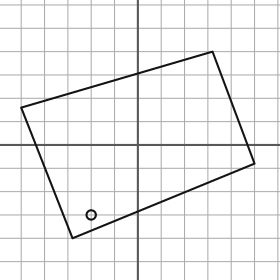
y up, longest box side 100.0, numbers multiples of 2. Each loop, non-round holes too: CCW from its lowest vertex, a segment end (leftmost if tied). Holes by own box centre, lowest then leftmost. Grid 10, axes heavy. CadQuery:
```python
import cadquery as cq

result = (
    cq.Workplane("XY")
    .moveTo(-28.0, -40.0)
    .lineTo(50.0, -8.0)
    .lineTo(32.0, 40.0)
    .lineTo(-50.0, 16.0)
    .close()
    .moveTo(-20.0, -30.0)
    .circle(2.0)
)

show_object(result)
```